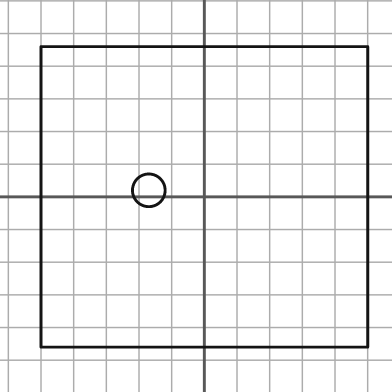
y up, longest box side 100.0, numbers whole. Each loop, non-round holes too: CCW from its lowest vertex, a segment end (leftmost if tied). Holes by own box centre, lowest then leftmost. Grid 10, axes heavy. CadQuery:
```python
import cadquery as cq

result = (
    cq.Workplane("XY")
    .moveTo(-50.0, -46.0)
    .lineTo(50.0, -46.0)
    .lineTo(50.0, 46.0)
    .lineTo(-50.0, 46.0)
    .close()
    .moveTo(-17.0, 2.0)
    .circle(5.0)
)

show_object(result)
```